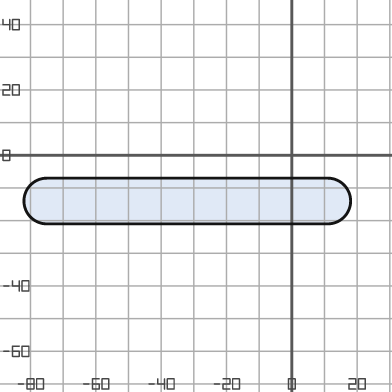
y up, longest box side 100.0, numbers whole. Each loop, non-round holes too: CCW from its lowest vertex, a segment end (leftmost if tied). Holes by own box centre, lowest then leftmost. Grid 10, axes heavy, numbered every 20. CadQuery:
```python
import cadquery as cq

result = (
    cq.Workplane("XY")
    .moveTo(-75.0, -21.0)
    .lineTo(11.0, -21.0)
    .threePointArc((18.0, -14.0), (11.0, -7.0))
    .lineTo(-75.0, -7.0)
    .threePointArc((-82.0, -14.0), (-75.0, -21.0))
    .close()
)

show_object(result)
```